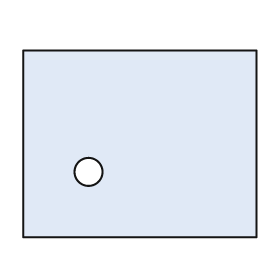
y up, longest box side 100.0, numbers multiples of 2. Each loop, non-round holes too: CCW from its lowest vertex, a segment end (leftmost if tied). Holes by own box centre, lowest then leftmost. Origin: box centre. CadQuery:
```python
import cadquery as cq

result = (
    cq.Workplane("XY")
    .moveTo(-50.0, -40.0)
    .lineTo(50.0, -40.0)
    .lineTo(50.0, 40.0)
    .lineTo(-50.0, 40.0)
    .close()
    .moveTo(-22.0, -12.0)
    .circle(6.0)
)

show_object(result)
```